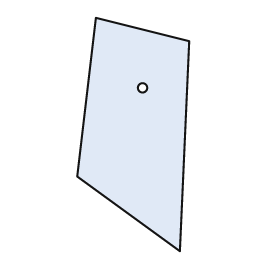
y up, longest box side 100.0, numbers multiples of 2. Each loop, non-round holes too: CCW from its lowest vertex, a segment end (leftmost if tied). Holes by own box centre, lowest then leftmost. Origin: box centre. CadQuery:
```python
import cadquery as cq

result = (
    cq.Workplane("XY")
    .moveTo(20.0, -50.0)
    .lineTo(24.0, 40.0)
    .lineTo(-16.0, 50.0)
    .lineTo(-24.0, -18.0)
    .close()
    .moveTo(4.0, 20.0)
    .circle(2.0)
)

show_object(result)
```